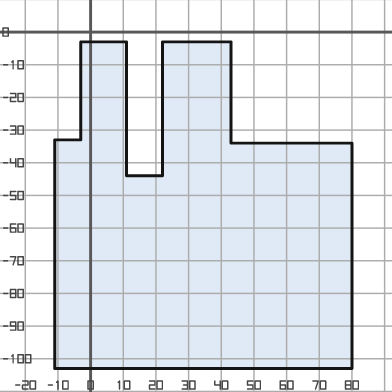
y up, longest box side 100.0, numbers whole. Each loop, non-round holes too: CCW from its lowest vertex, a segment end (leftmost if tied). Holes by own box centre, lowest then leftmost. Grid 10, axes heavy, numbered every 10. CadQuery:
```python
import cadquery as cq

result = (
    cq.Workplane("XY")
    .moveTo(-11.0, -103.0)
    .lineTo(80.0, -103.0)
    .lineTo(80.0, -34.0)
    .lineTo(43.0, -34.0)
    .lineTo(43.0, -3.0)
    .lineTo(22.0, -3.0)
    .lineTo(22.0, -44.0)
    .lineTo(11.0, -44.0)
    .lineTo(11.0, -3.0)
    .lineTo(-3.0, -3.0)
    .lineTo(-3.0, -33.0)
    .lineTo(-11.0, -33.0)
    .close()
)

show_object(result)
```